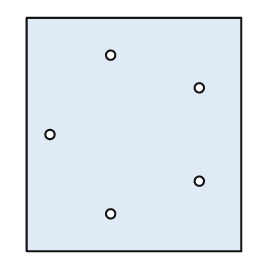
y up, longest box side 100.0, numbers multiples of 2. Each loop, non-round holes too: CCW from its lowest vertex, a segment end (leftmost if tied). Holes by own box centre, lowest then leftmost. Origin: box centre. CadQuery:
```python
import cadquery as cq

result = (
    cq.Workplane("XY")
    .moveTo(-46.0, -50.0)
    .lineTo(46.0, -50.0)
    .lineTo(46.0, 50.0)
    .lineTo(-46.0, 50.0)
    .close()
    .moveTo(-10.0, -34.0)
    .circle(2.0)
    .moveTo(28.0, -20.0)
    .circle(2.0)
    .moveTo(-36.0, 0.0)
    .circle(2.0)
    .moveTo(28.0, 20.0)
    .circle(2.0)
    .moveTo(-10.0, 34.0)
    .circle(2.0)
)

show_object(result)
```